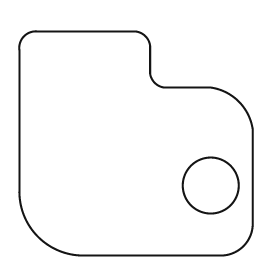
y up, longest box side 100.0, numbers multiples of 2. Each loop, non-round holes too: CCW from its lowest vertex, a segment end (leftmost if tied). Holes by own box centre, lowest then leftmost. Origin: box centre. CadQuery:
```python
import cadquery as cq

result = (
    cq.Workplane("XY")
    .moveTo(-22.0, -48.0)
    .lineTo(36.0, -48.0)
    .threePointArc((46.0, -44.0), (50.0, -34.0))
    .lineTo(50.0, 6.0)
    .threePointArc((44.0, 18.0), (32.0, 24.0))
    .lineTo(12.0, 24.0)
    .threePointArc((8.0, 26.0), (6.0, 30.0))
    .lineTo(6.0, 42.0)
    .threePointArc((4.0, 46.0), (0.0, 48.0))
    .lineTo(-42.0, 48.0)
    .threePointArc((-48.0, 46.0), (-50.0, 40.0))
    .lineTo(-50.0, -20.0)
    .threePointArc((-42.0, -40.0), (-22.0, -48.0))
    .close()
    .moveTo(32.0, -18.0)
    .circle(12.0)
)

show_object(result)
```